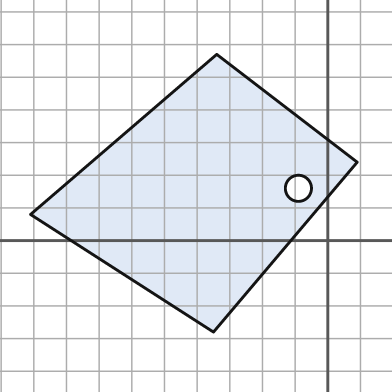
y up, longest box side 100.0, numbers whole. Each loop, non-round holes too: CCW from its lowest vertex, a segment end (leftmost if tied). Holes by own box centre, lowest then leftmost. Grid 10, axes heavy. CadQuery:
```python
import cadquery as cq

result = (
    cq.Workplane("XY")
    .moveTo(-35.0, -28.0)
    .lineTo(9.0, 24.0)
    .lineTo(-34.0, 57.0)
    .lineTo(-91.0, 8.0)
    .close()
    .moveTo(-9.0, 16.0)
    .circle(4.0)
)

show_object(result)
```